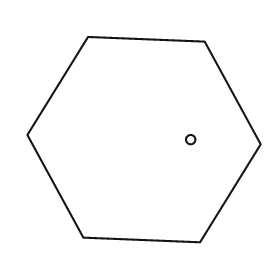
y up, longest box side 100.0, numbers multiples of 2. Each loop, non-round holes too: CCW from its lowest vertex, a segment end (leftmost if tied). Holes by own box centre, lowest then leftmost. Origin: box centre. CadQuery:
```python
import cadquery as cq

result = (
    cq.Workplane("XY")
    .moveTo(24.0, -44.0)
    .lineTo(50.0, -2.0)
    .lineTo(26.0, 42.0)
    .lineTo(-24.0, 44.0)
    .lineTo(-50.0, 2.0)
    .lineTo(-26.0, -42.0)
    .close()
    .moveTo(20.0, 0.0)
    .circle(2.0)
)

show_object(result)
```